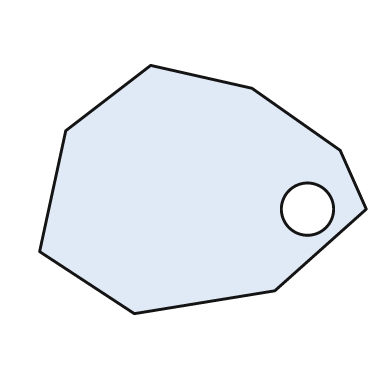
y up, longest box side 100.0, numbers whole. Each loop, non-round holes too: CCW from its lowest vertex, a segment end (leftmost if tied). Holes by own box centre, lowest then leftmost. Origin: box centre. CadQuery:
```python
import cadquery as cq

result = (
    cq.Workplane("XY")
    .moveTo(-21.0, -38.0)
    .lineTo(22.0, -31.0)
    .lineTo(50.0, -6.0)
    .lineTo(42.0, 12.0)
    .lineTo(15.0, 31.0)
    .lineTo(-16.0, 38.0)
    .lineTo(-42.0, 18.0)
    .lineTo(-50.0, -19.0)
    .close()
    .moveTo(32.0, -6.0)
    .circle(8.0)
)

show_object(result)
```